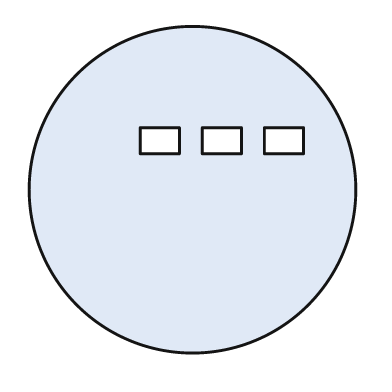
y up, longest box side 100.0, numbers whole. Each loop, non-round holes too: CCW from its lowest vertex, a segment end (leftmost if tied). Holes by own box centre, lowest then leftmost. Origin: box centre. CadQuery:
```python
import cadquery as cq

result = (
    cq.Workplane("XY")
    .moveTo(0.0, 0.0)
    .circle(50.0)
    .moveTo(-16.0, 11.0)
    .lineTo(-4.0, 11.0)
    .lineTo(-4.0, 19.0)
    .lineTo(-16.0, 19.0)
    .close()
    .moveTo(3.0, 11.0)
    .lineTo(15.0, 11.0)
    .lineTo(15.0, 19.0)
    .lineTo(3.0, 19.0)
    .close()
    .moveTo(22.0, 11.0)
    .lineTo(34.0, 11.0)
    .lineTo(34.0, 19.0)
    .lineTo(22.0, 19.0)
    .close()
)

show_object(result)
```